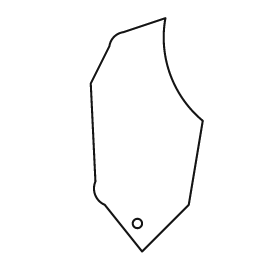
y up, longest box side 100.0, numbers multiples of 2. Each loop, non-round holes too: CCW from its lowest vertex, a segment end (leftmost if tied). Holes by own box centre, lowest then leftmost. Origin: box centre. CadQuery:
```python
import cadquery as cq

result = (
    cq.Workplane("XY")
    .moveTo(-2.0, -50.0)
    .lineTo(18.0, -30.0)
    .lineTo(24.0, 6.0)
    .threePointArc((10.0, 26.0), (8.0, 50.0))
    .lineTo(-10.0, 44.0)
    .threePointArc((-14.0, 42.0), (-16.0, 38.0))
    .lineTo(-24.0, 22.0)
    .lineTo(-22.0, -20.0)
    .threePointArc((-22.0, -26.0), (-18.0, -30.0))
    .close()
    .moveTo(-4.0, -38.0)
    .circle(2.0)
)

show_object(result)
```